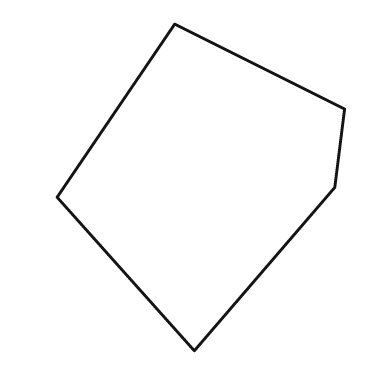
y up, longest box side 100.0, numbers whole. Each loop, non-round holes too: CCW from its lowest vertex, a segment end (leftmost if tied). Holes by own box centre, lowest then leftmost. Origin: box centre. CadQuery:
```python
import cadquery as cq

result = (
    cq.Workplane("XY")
    .moveTo(-2.0, -50.0)
    .lineTo(41.0, 0.0)
    .lineTo(44.0, 24.0)
    .lineTo(-8.0, 50.0)
    .lineTo(-44.0, -3.0)
    .close()
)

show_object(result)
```